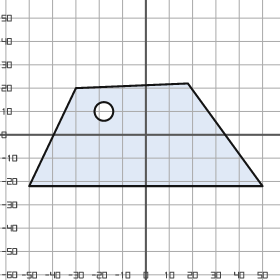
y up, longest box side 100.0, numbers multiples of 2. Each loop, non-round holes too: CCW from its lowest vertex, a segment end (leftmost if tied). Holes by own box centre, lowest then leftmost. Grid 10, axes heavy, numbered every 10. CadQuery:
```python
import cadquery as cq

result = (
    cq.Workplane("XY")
    .moveTo(-50.0, -22.0)
    .lineTo(50.0, -22.0)
    .lineTo(18.0, 22.0)
    .lineTo(-30.0, 20.0)
    .close()
    .moveTo(-18.0, 10.0)
    .circle(4.0)
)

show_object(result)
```